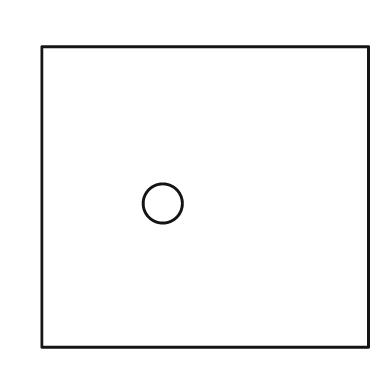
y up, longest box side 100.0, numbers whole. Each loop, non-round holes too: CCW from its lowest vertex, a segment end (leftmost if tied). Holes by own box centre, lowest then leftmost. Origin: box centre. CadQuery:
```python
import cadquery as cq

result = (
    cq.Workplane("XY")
    .moveTo(-50.0, -46.0)
    .lineTo(50.0, -46.0)
    .lineTo(50.0, 46.0)
    .lineTo(-50.0, 46.0)
    .close()
    .moveTo(-13.0, -2.0)
    .circle(6.0)
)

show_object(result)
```